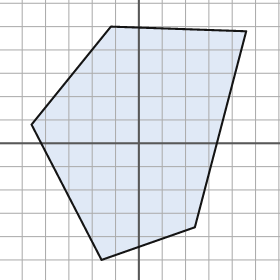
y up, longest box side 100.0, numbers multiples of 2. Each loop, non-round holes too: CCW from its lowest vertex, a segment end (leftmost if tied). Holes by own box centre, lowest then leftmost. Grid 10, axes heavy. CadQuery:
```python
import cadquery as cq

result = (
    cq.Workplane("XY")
    .moveTo(-16.0, -50.0)
    .lineTo(24.0, -36.0)
    .lineTo(46.0, 48.0)
    .lineTo(-12.0, 50.0)
    .lineTo(-46.0, 8.0)
    .close()
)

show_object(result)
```